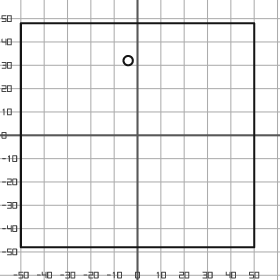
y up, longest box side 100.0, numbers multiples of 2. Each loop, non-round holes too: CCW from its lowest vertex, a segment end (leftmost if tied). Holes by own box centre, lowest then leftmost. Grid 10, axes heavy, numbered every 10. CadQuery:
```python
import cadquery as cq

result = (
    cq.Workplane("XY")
    .moveTo(-50.0, -48.0)
    .lineTo(50.0, -48.0)
    .lineTo(50.0, 48.0)
    .lineTo(-50.0, 48.0)
    .close()
    .moveTo(-4.0, 32.0)
    .circle(2.0)
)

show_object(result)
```